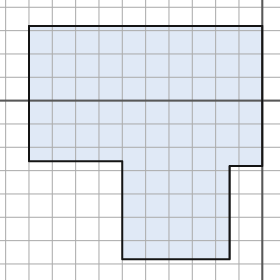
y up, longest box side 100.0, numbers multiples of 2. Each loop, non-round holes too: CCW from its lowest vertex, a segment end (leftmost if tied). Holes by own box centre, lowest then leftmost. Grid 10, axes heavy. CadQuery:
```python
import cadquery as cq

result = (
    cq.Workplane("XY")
    .moveTo(-60.0, -68.0)
    .lineTo(-14.0, -68.0)
    .lineTo(-14.0, -28.0)
    .lineTo(0.0, -28.0)
    .lineTo(0.0, 32.0)
    .lineTo(-100.0, 32.0)
    .lineTo(-100.0, -26.0)
    .lineTo(-60.0, -26.0)
    .close()
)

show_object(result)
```